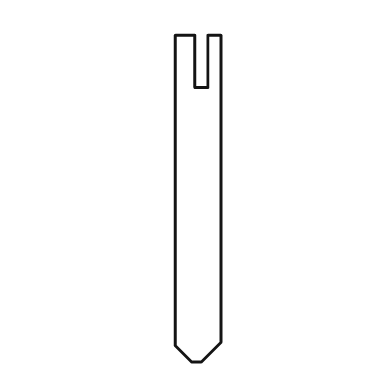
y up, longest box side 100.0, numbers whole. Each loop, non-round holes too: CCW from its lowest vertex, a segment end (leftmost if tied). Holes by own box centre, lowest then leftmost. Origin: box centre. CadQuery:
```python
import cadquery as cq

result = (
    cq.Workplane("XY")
    .moveTo(-2.0, -50.0)
    .lineTo(1.0, -50.0)
    .lineTo(7.0, -44.0)
    .lineTo(7.0, 50.0)
    .lineTo(3.0, 50.0)
    .lineTo(3.0, 34.0)
    .lineTo(-1.0, 34.0)
    .lineTo(-1.0, 50.0)
    .lineTo(-7.0, 50.0)
    .lineTo(-7.0, -45.0)
    .close()
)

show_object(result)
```